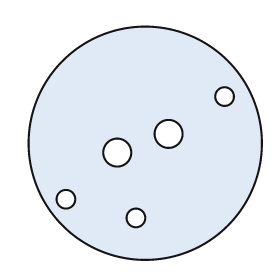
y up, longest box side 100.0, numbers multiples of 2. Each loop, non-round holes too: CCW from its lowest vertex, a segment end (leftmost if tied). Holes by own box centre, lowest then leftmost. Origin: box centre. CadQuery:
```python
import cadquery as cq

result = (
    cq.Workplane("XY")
    .moveTo(0.0, 0.0)
    .circle(50.0)
    .moveTo(-4.0, -32.0)
    .circle(4.0)
    .moveTo(-34.0, -24.0)
    .circle(4.0)
    .moveTo(-12.0, -4.0)
    .circle(6.0)
    .moveTo(10.0, 4.0)
    .circle(6.0)
    .moveTo(34.0, 20.0)
    .circle(4.0)
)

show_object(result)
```